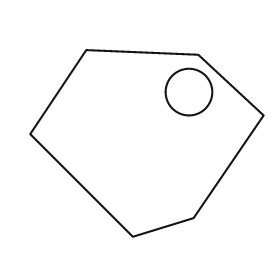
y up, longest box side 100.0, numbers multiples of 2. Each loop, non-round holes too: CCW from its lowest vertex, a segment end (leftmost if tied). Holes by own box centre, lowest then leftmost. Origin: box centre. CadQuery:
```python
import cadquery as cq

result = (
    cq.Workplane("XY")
    .moveTo(-6.0, -40.0)
    .lineTo(20.0, -32.0)
    .lineTo(50.0, 12.0)
    .lineTo(22.0, 38.0)
    .lineTo(-26.0, 40.0)
    .lineTo(-50.0, 4.0)
    .close()
    .moveTo(18.0, 22.0)
    .circle(10.0)
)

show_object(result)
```